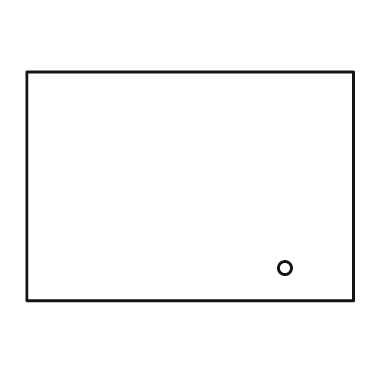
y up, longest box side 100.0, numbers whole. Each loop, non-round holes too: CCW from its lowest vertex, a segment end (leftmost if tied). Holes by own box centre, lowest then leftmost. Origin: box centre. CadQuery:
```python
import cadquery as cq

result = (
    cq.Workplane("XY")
    .moveTo(-50.0, -35.0)
    .lineTo(50.0, -35.0)
    .lineTo(50.0, 35.0)
    .lineTo(-50.0, 35.0)
    .close()
    .moveTo(29.0, -25.0)
    .circle(2.0)
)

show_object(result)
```